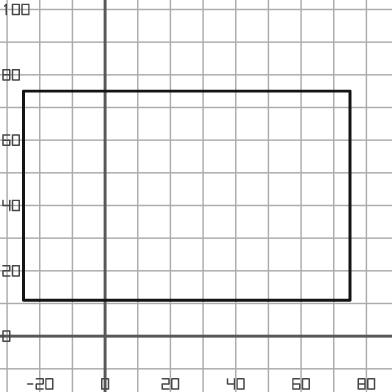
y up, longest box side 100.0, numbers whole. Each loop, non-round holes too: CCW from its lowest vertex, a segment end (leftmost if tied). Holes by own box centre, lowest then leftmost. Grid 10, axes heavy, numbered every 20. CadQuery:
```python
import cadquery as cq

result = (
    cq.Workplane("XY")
    .moveTo(-25.0, 11.0)
    .lineTo(75.0, 11.0)
    .lineTo(75.0, 75.0)
    .lineTo(-25.0, 75.0)
    .close()
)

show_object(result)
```